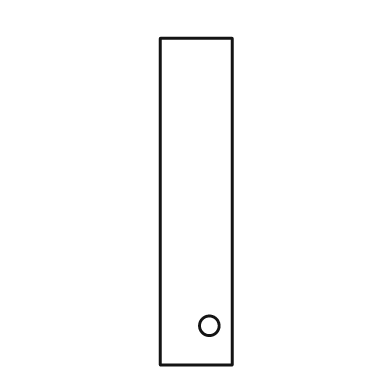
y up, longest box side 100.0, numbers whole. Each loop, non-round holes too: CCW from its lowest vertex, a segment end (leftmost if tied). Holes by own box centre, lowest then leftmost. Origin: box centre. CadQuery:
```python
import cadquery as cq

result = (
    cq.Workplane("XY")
    .moveTo(-11.0, -50.0)
    .lineTo(11.0, -50.0)
    .lineTo(11.0, 50.0)
    .lineTo(-11.0, 50.0)
    .close()
    .moveTo(4.0, -38.0)
    .circle(3.0)
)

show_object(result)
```